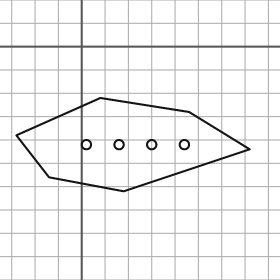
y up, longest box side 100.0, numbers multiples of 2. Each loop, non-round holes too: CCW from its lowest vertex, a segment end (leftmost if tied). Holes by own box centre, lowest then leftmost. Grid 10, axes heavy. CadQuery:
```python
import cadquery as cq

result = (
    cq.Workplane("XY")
    .moveTo(18.0, -62.0)
    .lineTo(72.0, -44.0)
    .lineTo(46.0, -28.0)
    .lineTo(8.0, -22.0)
    .lineTo(-28.0, -38.0)
    .lineTo(-14.0, -56.0)
    .close()
    .moveTo(2.0, -42.0)
    .circle(2.0)
    .moveTo(16.0, -42.0)
    .circle(2.0)
    .moveTo(30.0, -42.0)
    .circle(2.0)
    .moveTo(44.0, -42.0)
    .circle(2.0)
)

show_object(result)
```